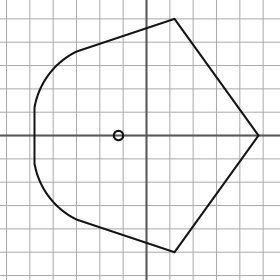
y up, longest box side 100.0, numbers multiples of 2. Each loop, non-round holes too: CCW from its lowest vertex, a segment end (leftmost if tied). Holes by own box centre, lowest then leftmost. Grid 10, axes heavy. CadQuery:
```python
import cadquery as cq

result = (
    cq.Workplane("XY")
    .moveTo(12.0, -50.0)
    .lineTo(48.0, 0.0)
    .lineTo(12.0, 50.0)
    .lineTo(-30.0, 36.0)
    .threePointArc((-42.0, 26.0), (-48.0, 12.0))
    .lineTo(-48.0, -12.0)
    .threePointArc((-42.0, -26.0), (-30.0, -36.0))
    .close()
    .moveTo(-12.0, 0.0)
    .circle(2.0)
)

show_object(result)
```